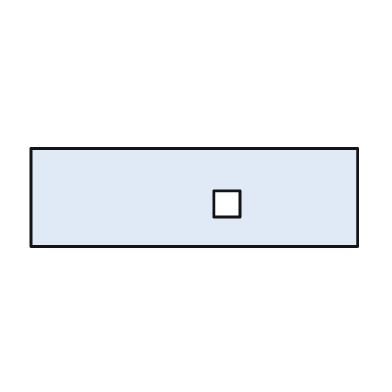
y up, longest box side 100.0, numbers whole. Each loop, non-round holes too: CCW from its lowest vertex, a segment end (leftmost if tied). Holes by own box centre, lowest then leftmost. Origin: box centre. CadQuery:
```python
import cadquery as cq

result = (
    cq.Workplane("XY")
    .moveTo(-50.0, -15.0)
    .lineTo(50.0, -15.0)
    .lineTo(50.0, 15.0)
    .lineTo(-50.0, 15.0)
    .close()
    .moveTo(6.0, -6.0)
    .lineTo(14.0, -6.0)
    .lineTo(14.0, 2.0)
    .lineTo(6.0, 2.0)
    .close()
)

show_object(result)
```